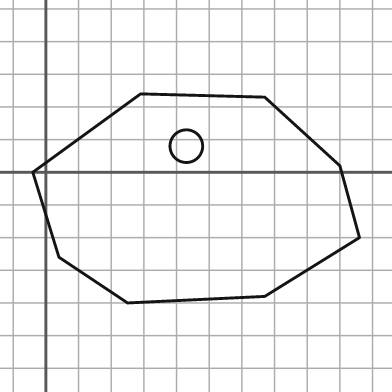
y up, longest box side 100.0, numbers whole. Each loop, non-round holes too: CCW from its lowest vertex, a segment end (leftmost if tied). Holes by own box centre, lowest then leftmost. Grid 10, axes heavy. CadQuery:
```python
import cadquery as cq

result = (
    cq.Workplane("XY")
    .moveTo(25.0, -40.0)
    .lineTo(67.0, -38.0)
    .lineTo(96.0, -20.0)
    .lineTo(90.0, 2.0)
    .lineTo(67.0, 23.0)
    .lineTo(29.0, 24.0)
    .lineTo(-4.0, 0.0)
    .lineTo(4.0, -26.0)
    .close()
    .moveTo(43.0, 8.0)
    .circle(5.0)
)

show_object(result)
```